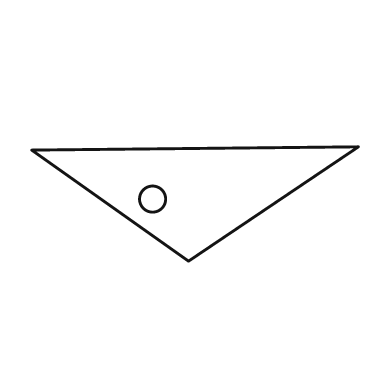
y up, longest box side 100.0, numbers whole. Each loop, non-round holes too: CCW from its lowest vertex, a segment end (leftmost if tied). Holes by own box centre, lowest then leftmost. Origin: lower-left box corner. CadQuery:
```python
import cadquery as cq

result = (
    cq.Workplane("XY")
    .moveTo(48.0, 0.0)
    .lineTo(100.0, 35.0)
    .lineTo(0.0, 34.0)
    .close()
    .moveTo(37.0, 19.0)
    .circle(4.0)
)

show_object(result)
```